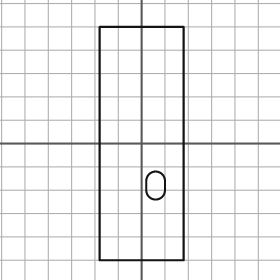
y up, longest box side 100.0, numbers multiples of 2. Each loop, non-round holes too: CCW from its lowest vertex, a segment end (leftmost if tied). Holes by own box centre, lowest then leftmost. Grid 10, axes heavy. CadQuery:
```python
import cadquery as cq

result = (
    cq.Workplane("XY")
    .moveTo(-18.0, -50.0)
    .lineTo(18.0, -50.0)
    .lineTo(18.0, 50.0)
    .lineTo(-18.0, 50.0)
    .close()
    .moveTo(2.0, -20.0)
    .threePointArc((6.0, -24.0), (10.0, -20.0))
    .lineTo(10.0, -16.0)
    .threePointArc((6.0, -12.0), (2.0, -16.0))
    .close()
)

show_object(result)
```